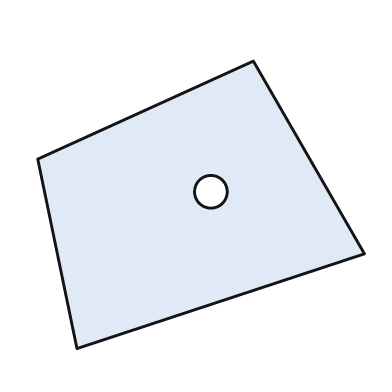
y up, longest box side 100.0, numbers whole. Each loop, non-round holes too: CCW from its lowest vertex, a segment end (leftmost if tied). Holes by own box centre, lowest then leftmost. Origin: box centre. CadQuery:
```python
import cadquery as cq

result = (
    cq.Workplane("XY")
    .moveTo(-38.0, -44.0)
    .lineTo(50.0, -15.0)
    .lineTo(16.0, 44.0)
    .lineTo(-50.0, 14.0)
    .close()
    .moveTo(3.0, 4.0)
    .circle(5.0)
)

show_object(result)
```